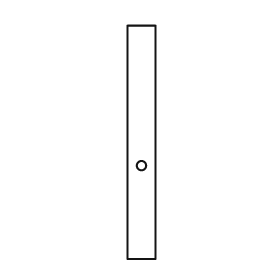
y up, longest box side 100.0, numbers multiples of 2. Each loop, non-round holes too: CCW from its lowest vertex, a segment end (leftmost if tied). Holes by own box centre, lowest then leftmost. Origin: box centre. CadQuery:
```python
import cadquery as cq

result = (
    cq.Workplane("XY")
    .moveTo(-6.0, -50.0)
    .lineTo(6.0, -50.0)
    .lineTo(6.0, 50.0)
    .lineTo(-6.0, 50.0)
    .close()
    .moveTo(0.0, -10.0)
    .circle(2.0)
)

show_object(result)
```